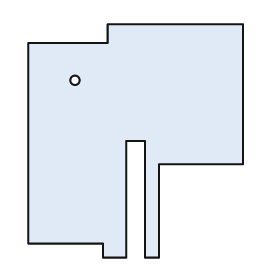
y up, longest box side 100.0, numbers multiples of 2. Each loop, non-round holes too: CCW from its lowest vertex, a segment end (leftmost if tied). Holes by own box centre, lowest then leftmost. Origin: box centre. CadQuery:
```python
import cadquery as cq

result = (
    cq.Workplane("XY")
    .moveTo(-14.0, -50.0)
    .lineTo(-4.0, -50.0)
    .lineTo(-4.0, 0.0)
    .lineTo(4.0, 0.0)
    .lineTo(4.0, -50.0)
    .lineTo(10.0, -50.0)
    .lineTo(10.0, -10.0)
    .lineTo(46.0, -10.0)
    .lineTo(46.0, 50.0)
    .lineTo(-12.0, 50.0)
    .lineTo(-12.0, 42.0)
    .lineTo(-46.0, 42.0)
    .lineTo(-46.0, -44.0)
    .lineTo(-14.0, -44.0)
    .close()
    .moveTo(-26.0, 26.0)
    .circle(2.0)
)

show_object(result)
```